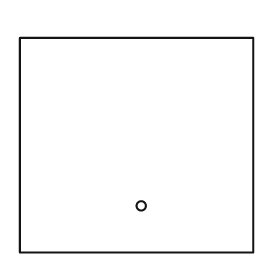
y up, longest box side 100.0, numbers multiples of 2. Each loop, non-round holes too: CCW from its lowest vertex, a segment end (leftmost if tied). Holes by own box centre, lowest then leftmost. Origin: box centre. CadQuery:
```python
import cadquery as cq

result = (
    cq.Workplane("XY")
    .moveTo(-50.0, -46.0)
    .lineTo(50.0, -46.0)
    .lineTo(50.0, 46.0)
    .lineTo(-50.0, 46.0)
    .close()
    .moveTo(2.0, -26.0)
    .circle(2.0)
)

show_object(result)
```